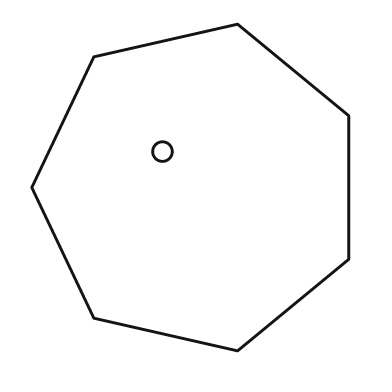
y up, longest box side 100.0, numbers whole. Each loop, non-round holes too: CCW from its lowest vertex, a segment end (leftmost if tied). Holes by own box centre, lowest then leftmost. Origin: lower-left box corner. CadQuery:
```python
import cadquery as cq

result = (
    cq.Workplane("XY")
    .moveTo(63.0, 0.0)
    .lineTo(97.0, 28.0)
    .lineTo(97.0, 72.0)
    .lineTo(63.0, 100.0)
    .lineTo(19.0, 90.0)
    .lineTo(0.0, 50.0)
    .lineTo(19.0, 10.0)
    .close()
    .moveTo(40.0, 61.0)
    .circle(3.0)
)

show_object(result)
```